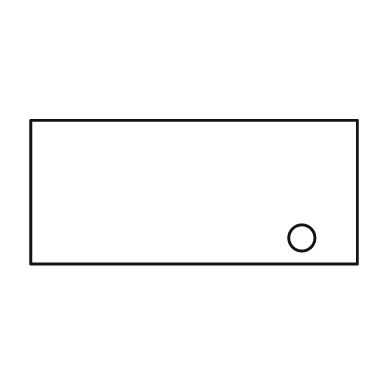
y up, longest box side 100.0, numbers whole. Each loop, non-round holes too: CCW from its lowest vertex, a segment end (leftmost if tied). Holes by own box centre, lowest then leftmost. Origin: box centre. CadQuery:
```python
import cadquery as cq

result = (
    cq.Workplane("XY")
    .moveTo(-50.0, -22.0)
    .lineTo(50.0, -22.0)
    .lineTo(50.0, 22.0)
    .lineTo(-50.0, 22.0)
    .close()
    .moveTo(33.0, -14.0)
    .circle(4.0)
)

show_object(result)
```